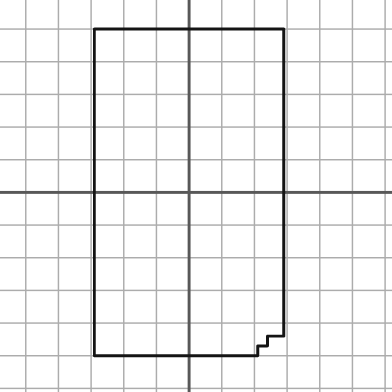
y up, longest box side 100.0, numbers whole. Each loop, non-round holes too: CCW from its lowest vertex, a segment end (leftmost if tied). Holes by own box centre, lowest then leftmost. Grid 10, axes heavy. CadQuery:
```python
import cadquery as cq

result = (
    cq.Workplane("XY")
    .moveTo(-29.0, -50.0)
    .lineTo(21.0, -50.0)
    .lineTo(21.0, -47.0)
    .lineTo(24.0, -47.0)
    .lineTo(24.0, -44.0)
    .lineTo(29.0, -44.0)
    .lineTo(29.0, 50.0)
    .lineTo(-29.0, 50.0)
    .close()
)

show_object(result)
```